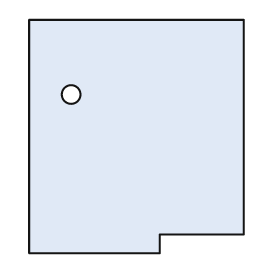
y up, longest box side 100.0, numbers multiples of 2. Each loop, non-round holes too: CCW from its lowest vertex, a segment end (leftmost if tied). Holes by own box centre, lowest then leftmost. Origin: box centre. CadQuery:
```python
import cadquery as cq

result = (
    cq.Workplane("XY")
    .moveTo(-46.0, -50.0)
    .lineTo(10.0, -50.0)
    .lineTo(10.0, -42.0)
    .lineTo(46.0, -42.0)
    .lineTo(46.0, 50.0)
    .lineTo(-46.0, 50.0)
    .close()
    .moveTo(-28.0, 18.0)
    .circle(4.0)
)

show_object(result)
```